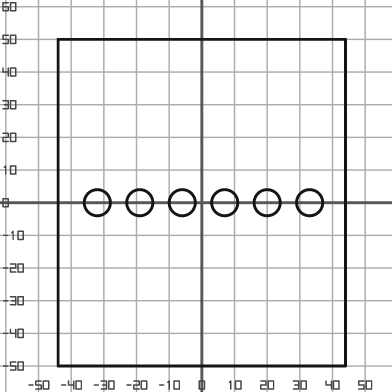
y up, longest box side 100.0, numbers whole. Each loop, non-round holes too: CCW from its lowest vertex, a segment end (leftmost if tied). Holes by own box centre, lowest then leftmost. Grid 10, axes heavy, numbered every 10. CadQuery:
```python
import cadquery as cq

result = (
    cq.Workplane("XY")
    .moveTo(-44.0, -50.0)
    .lineTo(44.0, -50.0)
    .lineTo(44.0, 50.0)
    .lineTo(-44.0, 50.0)
    .close()
    .moveTo(-32.0, 0.0)
    .circle(4.0)
    .moveTo(-19.0, 0.0)
    .circle(4.0)
    .moveTo(-6.0, 0.0)
    .circle(4.0)
    .moveTo(7.0, 0.0)
    .circle(4.0)
    .moveTo(20.0, 0.0)
    .circle(4.0)
    .moveTo(33.0, 0.0)
    .circle(4.0)
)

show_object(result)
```